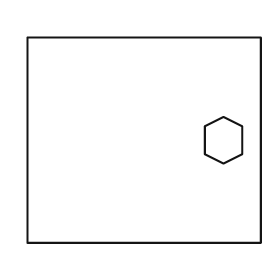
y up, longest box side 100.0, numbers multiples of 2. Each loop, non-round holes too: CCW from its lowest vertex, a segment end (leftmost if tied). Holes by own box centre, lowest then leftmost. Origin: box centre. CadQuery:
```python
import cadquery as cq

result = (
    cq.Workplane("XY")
    .moveTo(-50.0, -44.0)
    .lineTo(50.0, -44.0)
    .lineTo(50.0, 44.0)
    .lineTo(-50.0, 44.0)
    .close()
    .moveTo(34.0, -10.0)
    .lineTo(42.0, -6.0)
    .lineTo(42.0, 6.0)
    .lineTo(34.0, 10.0)
    .lineTo(26.0, 6.0)
    .lineTo(26.0, -6.0)
    .close()
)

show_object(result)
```